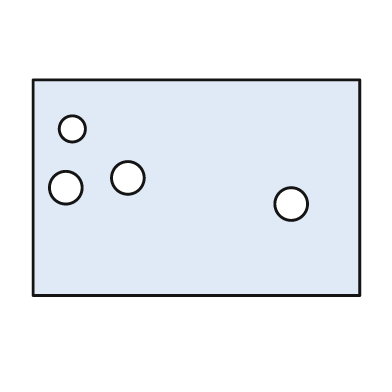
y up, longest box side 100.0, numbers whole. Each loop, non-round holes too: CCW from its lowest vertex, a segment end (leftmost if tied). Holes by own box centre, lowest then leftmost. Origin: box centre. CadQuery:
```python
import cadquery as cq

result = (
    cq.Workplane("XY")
    .moveTo(-50.0, -33.0)
    .lineTo(50.0, -33.0)
    .lineTo(50.0, 33.0)
    .lineTo(-50.0, 33.0)
    .close()
    .moveTo(29.0, -5.0)
    .circle(5.0)
    .moveTo(-40.0, 0.0)
    .circle(5.0)
    .moveTo(-21.0, 3.0)
    .circle(5.0)
    .moveTo(-38.0, 18.0)
    .circle(4.0)
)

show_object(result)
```